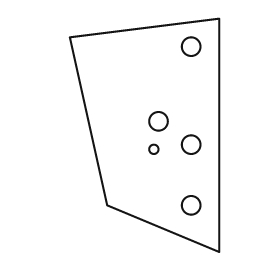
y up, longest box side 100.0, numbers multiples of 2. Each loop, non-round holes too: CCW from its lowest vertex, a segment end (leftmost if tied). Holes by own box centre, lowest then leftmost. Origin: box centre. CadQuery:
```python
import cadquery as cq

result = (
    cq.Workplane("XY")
    .moveTo(32.0, -50.0)
    .lineTo(32.0, 50.0)
    .lineTo(-32.0, 42.0)
    .lineTo(-16.0, -30.0)
    .close()
    .moveTo(20.0, -30.0)
    .circle(4.0)
    .moveTo(4.0, -6.0)
    .circle(2.0)
    .moveTo(20.0, -4.0)
    .circle(4.0)
    .moveTo(6.0, 6.0)
    .circle(4.0)
    .moveTo(20.0, 38.0)
    .circle(4.0)
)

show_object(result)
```